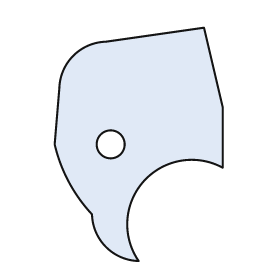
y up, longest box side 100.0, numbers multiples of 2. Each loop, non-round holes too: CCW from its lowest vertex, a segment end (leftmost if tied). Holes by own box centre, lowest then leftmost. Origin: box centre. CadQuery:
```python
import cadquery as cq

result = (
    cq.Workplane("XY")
    .moveTo(0.0, -50.0)
    .threePointArc((2.0, -16.0), (36.0, -10.0))
    .lineTo(36.0, 16.0)
    .lineTo(28.0, 50.0)
    .lineTo(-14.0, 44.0)
    .threePointArc((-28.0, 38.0), (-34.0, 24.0))
    .lineTo(-36.0, 0.0)
    .threePointArc((-30.0, -16.0), (-20.0, -30.0))
    .threePointArc((-14.0, -44.0), (0.0, -50.0))
    .close()
    .moveTo(-12.0, 0.0)
    .circle(6.0)
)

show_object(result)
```